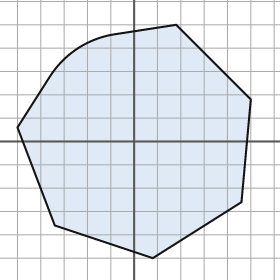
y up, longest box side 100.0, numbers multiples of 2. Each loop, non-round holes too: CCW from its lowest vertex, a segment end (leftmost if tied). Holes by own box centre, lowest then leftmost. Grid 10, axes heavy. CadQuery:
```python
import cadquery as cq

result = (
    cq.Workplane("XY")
    .moveTo(8.0, -50.0)
    .lineTo(46.0, -26.0)
    .lineTo(50.0, 18.0)
    .lineTo(18.0, 50.0)
    .lineTo(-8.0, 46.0)
    .threePointArc((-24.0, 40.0), (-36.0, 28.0))
    .lineTo(-50.0, 6.0)
    .lineTo(-34.0, -36.0)
    .close()
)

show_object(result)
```